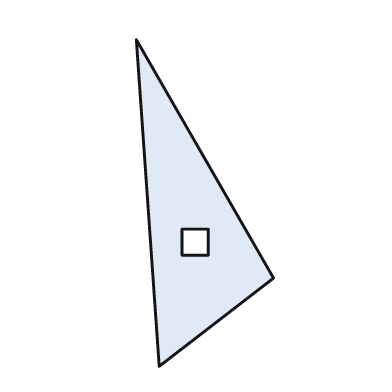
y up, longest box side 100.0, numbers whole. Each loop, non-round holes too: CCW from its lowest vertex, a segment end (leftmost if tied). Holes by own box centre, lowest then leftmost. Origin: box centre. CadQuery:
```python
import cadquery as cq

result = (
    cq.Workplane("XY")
    .moveTo(-14.0, -50.0)
    .lineTo(21.0, -23.0)
    .lineTo(-21.0, 50.0)
    .close()
    .moveTo(-7.0, -16.0)
    .lineTo(1.0, -16.0)
    .lineTo(1.0, -8.0)
    .lineTo(-7.0, -8.0)
    .close()
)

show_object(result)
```